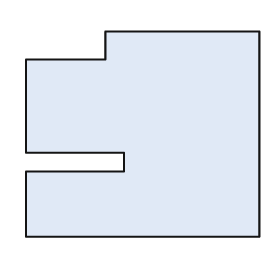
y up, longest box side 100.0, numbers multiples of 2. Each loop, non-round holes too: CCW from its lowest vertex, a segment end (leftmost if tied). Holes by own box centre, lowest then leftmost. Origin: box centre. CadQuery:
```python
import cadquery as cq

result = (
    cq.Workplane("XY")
    .moveTo(-50.0, -44.0)
    .lineTo(50.0, -44.0)
    .lineTo(50.0, 44.0)
    .lineTo(-16.0, 44.0)
    .lineTo(-16.0, 32.0)
    .lineTo(-50.0, 32.0)
    .lineTo(-50.0, -8.0)
    .lineTo(-8.0, -8.0)
    .lineTo(-8.0, -16.0)
    .lineTo(-50.0, -16.0)
    .close()
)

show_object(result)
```